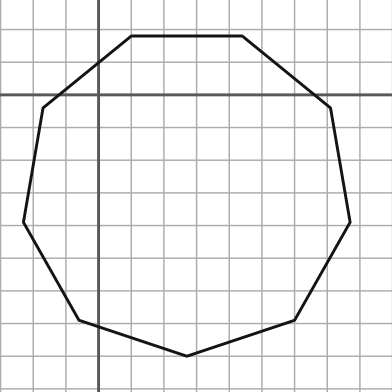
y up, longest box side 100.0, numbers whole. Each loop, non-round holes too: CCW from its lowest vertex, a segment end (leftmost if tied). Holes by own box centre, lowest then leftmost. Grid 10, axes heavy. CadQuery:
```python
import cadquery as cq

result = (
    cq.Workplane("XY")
    .moveTo(27.0, -80.0)
    .lineTo(60.0, -69.0)
    .lineTo(77.0, -39.0)
    .lineTo(71.0, -4.0)
    .lineTo(44.0, 18.0)
    .lineTo(10.0, 18.0)
    .lineTo(-17.0, -4.0)
    .lineTo(-23.0, -39.0)
    .lineTo(-6.0, -69.0)
    .close()
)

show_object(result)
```